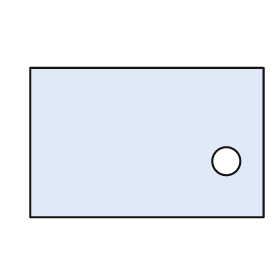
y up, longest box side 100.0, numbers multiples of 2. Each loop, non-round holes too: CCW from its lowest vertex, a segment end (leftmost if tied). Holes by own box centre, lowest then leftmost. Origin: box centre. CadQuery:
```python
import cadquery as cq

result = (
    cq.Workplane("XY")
    .moveTo(-50.0, -32.0)
    .lineTo(50.0, -32.0)
    .lineTo(50.0, 32.0)
    .lineTo(-50.0, 32.0)
    .close()
    .moveTo(34.0, -8.0)
    .circle(6.0)
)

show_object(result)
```